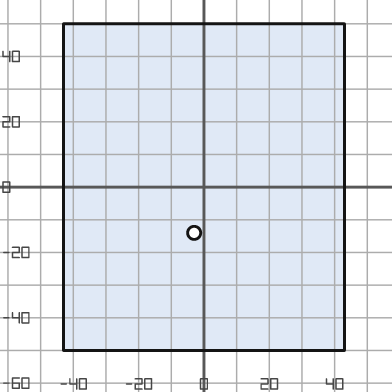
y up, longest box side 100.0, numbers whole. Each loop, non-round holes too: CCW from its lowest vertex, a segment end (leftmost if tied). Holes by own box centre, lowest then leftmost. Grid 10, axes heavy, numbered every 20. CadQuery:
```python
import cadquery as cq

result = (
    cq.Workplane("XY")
    .moveTo(-43.0, -50.0)
    .lineTo(43.0, -50.0)
    .lineTo(43.0, 50.0)
    .lineTo(-43.0, 50.0)
    .close()
    .moveTo(-3.0, -14.0)
    .circle(2.0)
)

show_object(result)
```